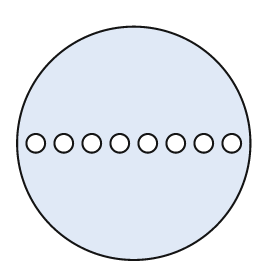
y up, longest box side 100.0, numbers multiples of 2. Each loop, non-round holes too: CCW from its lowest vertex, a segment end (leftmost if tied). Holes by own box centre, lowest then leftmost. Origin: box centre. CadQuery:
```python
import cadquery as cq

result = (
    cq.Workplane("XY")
    .moveTo(0.0, 0.0)
    .circle(50.0)
    .moveTo(-42.0, 0.0)
    .circle(4.0)
    .moveTo(-30.0, 0.0)
    .circle(4.0)
    .moveTo(-18.0, 0.0)
    .circle(4.0)
    .moveTo(-6.0, 0.0)
    .circle(4.0)
    .moveTo(6.0, 0.0)
    .circle(4.0)
    .moveTo(18.0, 0.0)
    .circle(4.0)
    .moveTo(30.0, 0.0)
    .circle(4.0)
    .moveTo(42.0, 0.0)
    .circle(4.0)
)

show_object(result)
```